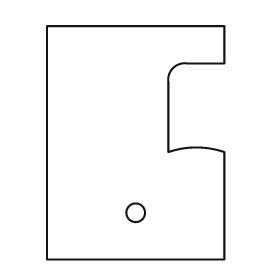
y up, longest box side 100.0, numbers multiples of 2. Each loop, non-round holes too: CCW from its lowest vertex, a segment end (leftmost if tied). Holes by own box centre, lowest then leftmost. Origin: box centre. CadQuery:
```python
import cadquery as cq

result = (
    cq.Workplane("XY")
    .moveTo(-38.0, -50.0)
    .lineTo(38.0, -50.0)
    .lineTo(38.0, -4.0)
    .threePointArc((26.0, -2.0), (14.0, -4.0))
    .lineTo(14.0, 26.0)
    .threePointArc((16.0, 32.0), (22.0, 34.0))
    .lineTo(38.0, 34.0)
    .lineTo(38.0, 50.0)
    .lineTo(-38.0, 50.0)
    .close()
    .moveTo(0.0, -30.0)
    .circle(4.0)
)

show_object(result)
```